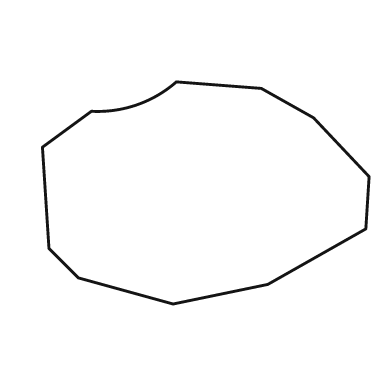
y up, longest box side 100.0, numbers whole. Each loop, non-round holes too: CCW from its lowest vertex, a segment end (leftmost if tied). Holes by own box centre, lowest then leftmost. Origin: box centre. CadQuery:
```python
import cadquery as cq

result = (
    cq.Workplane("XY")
    .moveTo(-10.0, -34.0)
    .lineTo(19.0, -28.0)
    .lineTo(49.0, -11.0)
    .lineTo(50.0, 5.0)
    .lineTo(33.0, 23.0)
    .lineTo(17.0, 32.0)
    .lineTo(-9.0, 34.0)
    .threePointArc((-21.0, 27.0), (-35.0, 25.0))
    .lineTo(-50.0, 14.0)
    .lineTo(-48.0, -17.0)
    .lineTo(-39.0, -26.0)
    .close()
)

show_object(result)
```